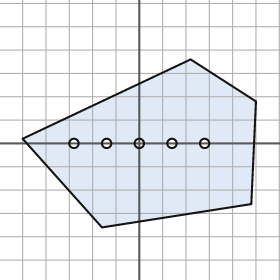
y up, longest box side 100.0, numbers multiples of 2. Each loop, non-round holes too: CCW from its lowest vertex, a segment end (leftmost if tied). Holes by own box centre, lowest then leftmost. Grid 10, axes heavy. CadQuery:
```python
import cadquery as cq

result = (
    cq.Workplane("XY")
    .moveTo(-16.0, -36.0)
    .lineTo(48.0, -26.0)
    .lineTo(50.0, 18.0)
    .lineTo(22.0, 36.0)
    .lineTo(-50.0, 2.0)
    .close()
    .moveTo(-28.0, 0.0)
    .circle(2.0)
    .moveTo(-14.0, 0.0)
    .circle(2.0)
    .moveTo(0.0, 0.0)
    .circle(2.0)
    .moveTo(14.0, 0.0)
    .circle(2.0)
    .moveTo(28.0, 0.0)
    .circle(2.0)
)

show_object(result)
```